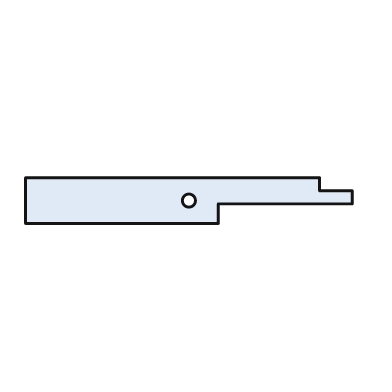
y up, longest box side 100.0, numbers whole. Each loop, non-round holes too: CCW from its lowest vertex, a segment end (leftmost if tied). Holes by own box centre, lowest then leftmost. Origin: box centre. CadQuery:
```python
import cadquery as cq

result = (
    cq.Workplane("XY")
    .moveTo(-50.0, -7.0)
    .lineTo(9.0, -7.0)
    .lineTo(9.0, -1.0)
    .lineTo(50.0, -1.0)
    .lineTo(50.0, 3.0)
    .lineTo(40.0, 3.0)
    .lineTo(40.0, 7.0)
    .lineTo(-50.0, 7.0)
    .close()
    .moveTo(0.0, 0.0)
    .circle(2.0)
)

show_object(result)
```